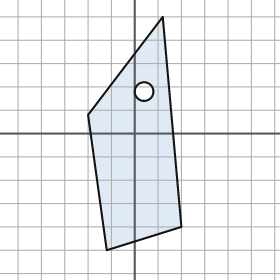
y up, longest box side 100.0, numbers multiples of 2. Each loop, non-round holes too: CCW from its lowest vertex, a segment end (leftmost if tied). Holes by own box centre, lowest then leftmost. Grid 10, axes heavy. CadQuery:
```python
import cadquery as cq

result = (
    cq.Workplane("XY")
    .moveTo(-12.0, -50.0)
    .lineTo(20.0, -40.0)
    .lineTo(12.0, 50.0)
    .lineTo(-20.0, 8.0)
    .close()
    .moveTo(4.0, 18.0)
    .circle(4.0)
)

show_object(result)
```